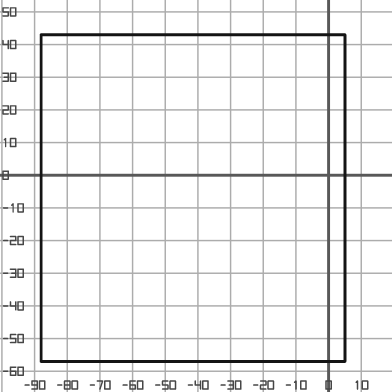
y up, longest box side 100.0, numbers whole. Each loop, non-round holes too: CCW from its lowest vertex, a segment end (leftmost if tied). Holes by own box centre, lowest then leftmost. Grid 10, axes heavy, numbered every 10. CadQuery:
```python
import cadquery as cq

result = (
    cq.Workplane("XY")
    .moveTo(-88.0, -57.0)
    .lineTo(5.0, -57.0)
    .lineTo(5.0, 43.0)
    .lineTo(-88.0, 43.0)
    .close()
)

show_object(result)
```